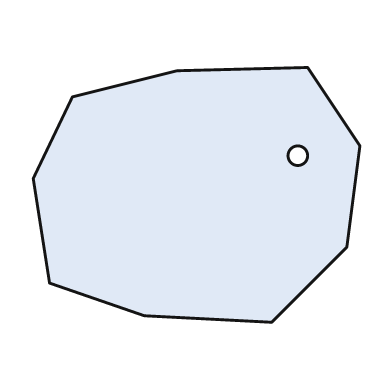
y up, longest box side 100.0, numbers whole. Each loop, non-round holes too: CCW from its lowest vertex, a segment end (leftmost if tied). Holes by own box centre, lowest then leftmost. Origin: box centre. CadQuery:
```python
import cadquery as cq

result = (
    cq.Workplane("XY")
    .moveTo(23.0, -39.0)
    .lineTo(46.0, -16.0)
    .lineTo(50.0, 15.0)
    .lineTo(34.0, 39.0)
    .lineTo(-6.0, 38.0)
    .lineTo(-38.0, 30.0)
    .lineTo(-50.0, 5.0)
    .lineTo(-45.0, -27.0)
    .lineTo(-16.0, -37.0)
    .close()
    .moveTo(31.0, 12.0)
    .circle(3.0)
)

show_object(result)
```